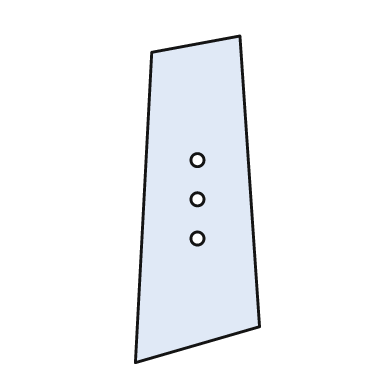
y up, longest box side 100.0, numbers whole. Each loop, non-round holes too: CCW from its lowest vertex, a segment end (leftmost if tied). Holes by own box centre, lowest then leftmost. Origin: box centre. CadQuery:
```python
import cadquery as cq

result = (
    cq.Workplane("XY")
    .moveTo(-19.0, -50.0)
    .lineTo(19.0, -39.0)
    .lineTo(13.0, 50.0)
    .lineTo(-14.0, 45.0)
    .close()
    .moveTo(0.0, -12.0)
    .circle(2.0)
    .moveTo(0.0, 0.0)
    .circle(2.0)
    .moveTo(0.0, 12.0)
    .circle(2.0)
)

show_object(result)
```